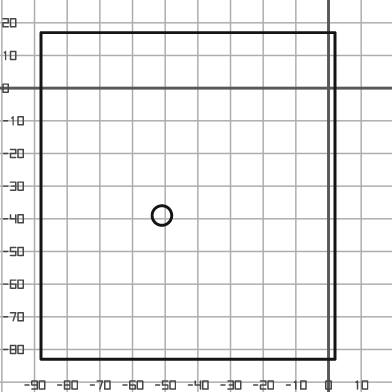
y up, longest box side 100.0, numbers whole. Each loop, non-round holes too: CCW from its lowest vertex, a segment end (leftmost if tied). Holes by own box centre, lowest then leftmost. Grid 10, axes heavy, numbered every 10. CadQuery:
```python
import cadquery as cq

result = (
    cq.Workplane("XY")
    .moveTo(-88.0, -83.0)
    .lineTo(2.0, -83.0)
    .lineTo(2.0, 17.0)
    .lineTo(-88.0, 17.0)
    .close()
    .moveTo(-51.0, -39.0)
    .circle(3.0)
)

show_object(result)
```